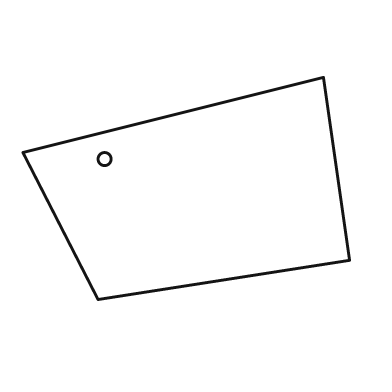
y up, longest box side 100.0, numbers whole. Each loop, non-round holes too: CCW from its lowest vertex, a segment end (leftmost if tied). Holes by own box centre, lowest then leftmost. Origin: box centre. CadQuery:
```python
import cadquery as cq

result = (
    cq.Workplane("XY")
    .moveTo(-27.0, -34.0)
    .lineTo(50.0, -22.0)
    .lineTo(42.0, 34.0)
    .lineTo(-50.0, 11.0)
    .close()
    .moveTo(-25.0, 9.0)
    .circle(2.0)
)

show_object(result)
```